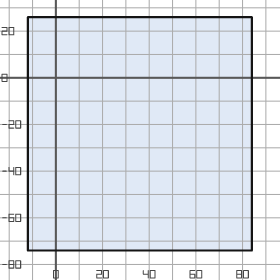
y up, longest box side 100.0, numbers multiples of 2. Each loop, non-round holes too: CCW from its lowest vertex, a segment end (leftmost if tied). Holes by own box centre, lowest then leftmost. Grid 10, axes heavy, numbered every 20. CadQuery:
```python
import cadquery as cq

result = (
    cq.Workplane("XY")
    .moveTo(-12.0, -74.0)
    .lineTo(84.0, -74.0)
    .lineTo(84.0, 26.0)
    .lineTo(-12.0, 26.0)
    .close()
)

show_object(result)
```